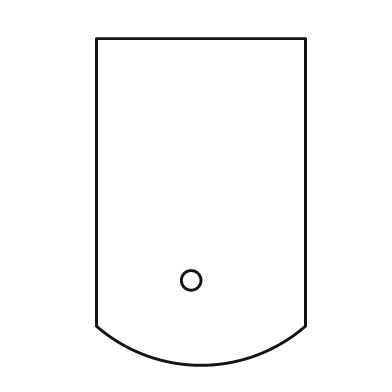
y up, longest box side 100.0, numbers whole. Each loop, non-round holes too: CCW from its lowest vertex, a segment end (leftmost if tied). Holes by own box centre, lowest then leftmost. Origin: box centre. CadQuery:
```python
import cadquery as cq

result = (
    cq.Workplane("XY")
    .moveTo(-32.0, -38.0)
    .threePointArc((0.0, -50.0), (32.0, -38.0))
    .lineTo(32.0, 50.0)
    .lineTo(-32.0, 50.0)
    .close()
    .moveTo(-3.0, -24.0)
    .circle(3.0)
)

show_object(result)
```